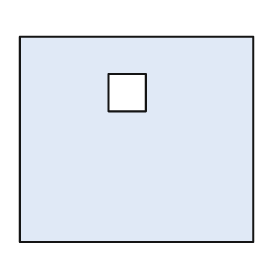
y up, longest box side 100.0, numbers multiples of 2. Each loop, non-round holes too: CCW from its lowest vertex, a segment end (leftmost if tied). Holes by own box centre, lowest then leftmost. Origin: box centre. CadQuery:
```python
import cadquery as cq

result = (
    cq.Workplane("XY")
    .moveTo(-50.0, -44.0)
    .lineTo(50.0, -44.0)
    .lineTo(50.0, 44.0)
    .lineTo(-50.0, 44.0)
    .close()
    .moveTo(-12.0, 12.0)
    .lineTo(4.0, 12.0)
    .lineTo(4.0, 28.0)
    .lineTo(-12.0, 28.0)
    .close()
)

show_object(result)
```